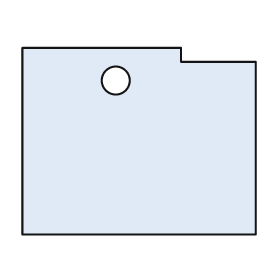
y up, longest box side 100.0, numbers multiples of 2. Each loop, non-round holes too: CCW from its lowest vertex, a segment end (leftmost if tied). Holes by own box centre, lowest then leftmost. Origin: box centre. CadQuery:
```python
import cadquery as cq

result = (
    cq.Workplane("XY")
    .moveTo(-50.0, -40.0)
    .lineTo(50.0, -40.0)
    .lineTo(50.0, 34.0)
    .lineTo(18.0, 34.0)
    .lineTo(18.0, 40.0)
    .lineTo(-50.0, 40.0)
    .close()
    .moveTo(-10.0, 26.0)
    .circle(6.0)
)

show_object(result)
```